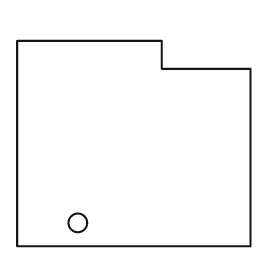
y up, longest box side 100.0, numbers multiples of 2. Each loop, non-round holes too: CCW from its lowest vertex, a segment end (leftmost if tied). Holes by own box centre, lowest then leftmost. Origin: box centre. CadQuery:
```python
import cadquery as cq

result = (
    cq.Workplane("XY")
    .moveTo(-50.0, -44.0)
    .lineTo(50.0, -44.0)
    .lineTo(50.0, 32.0)
    .lineTo(12.0, 32.0)
    .lineTo(12.0, 44.0)
    .lineTo(-50.0, 44.0)
    .close()
    .moveTo(-24.0, -34.0)
    .circle(4.0)
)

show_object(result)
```